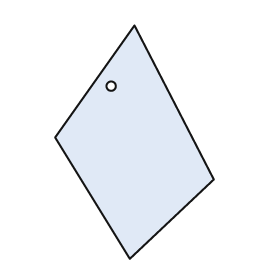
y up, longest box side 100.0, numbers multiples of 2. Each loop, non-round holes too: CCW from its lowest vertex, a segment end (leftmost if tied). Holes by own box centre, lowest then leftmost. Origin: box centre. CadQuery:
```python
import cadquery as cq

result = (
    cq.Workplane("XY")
    .moveTo(-2.0, -50.0)
    .lineTo(34.0, -16.0)
    .lineTo(0.0, 50.0)
    .lineTo(-34.0, 2.0)
    .close()
    .moveTo(-10.0, 24.0)
    .circle(2.0)
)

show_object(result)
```